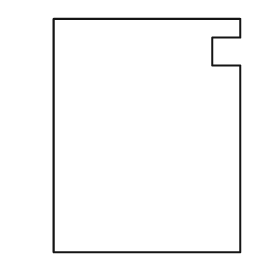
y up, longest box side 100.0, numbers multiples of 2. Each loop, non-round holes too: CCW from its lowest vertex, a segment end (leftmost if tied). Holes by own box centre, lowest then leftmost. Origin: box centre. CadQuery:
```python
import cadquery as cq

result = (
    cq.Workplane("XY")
    .moveTo(-40.0, -50.0)
    .lineTo(40.0, -50.0)
    .lineTo(40.0, 30.0)
    .lineTo(28.0, 30.0)
    .lineTo(28.0, 42.0)
    .lineTo(40.0, 42.0)
    .lineTo(40.0, 50.0)
    .lineTo(-40.0, 50.0)
    .close()
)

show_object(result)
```